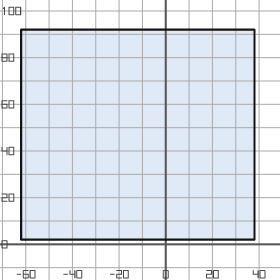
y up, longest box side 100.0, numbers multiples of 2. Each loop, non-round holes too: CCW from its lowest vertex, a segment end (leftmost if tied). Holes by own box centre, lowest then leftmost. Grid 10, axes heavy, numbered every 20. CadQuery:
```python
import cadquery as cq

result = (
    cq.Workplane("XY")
    .moveTo(-62.0, 2.0)
    .lineTo(38.0, 2.0)
    .lineTo(38.0, 92.0)
    .lineTo(-62.0, 92.0)
    .close()
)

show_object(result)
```